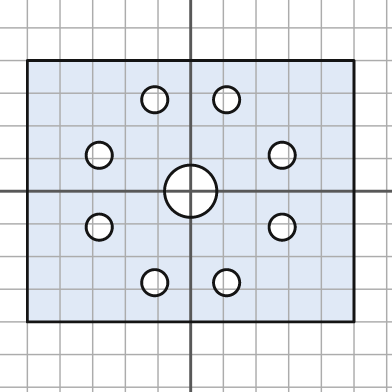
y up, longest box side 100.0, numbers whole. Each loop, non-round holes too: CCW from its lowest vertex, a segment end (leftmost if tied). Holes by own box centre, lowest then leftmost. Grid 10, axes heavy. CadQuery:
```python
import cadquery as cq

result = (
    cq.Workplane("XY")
    .moveTo(-50.0, -40.0)
    .lineTo(50.0, -40.0)
    .lineTo(50.0, 40.0)
    .lineTo(-50.0, 40.0)
    .close()
    .moveTo(-11.0, -28.0)
    .circle(4.0)
    .moveTo(11.0, -28.0)
    .circle(4.0)
    .moveTo(-28.0, -11.0)
    .circle(4.0)
    .moveTo(28.0, -11.0)
    .circle(4.0)
    .moveTo(0.0, 0.0)
    .circle(8.0)
    .moveTo(-28.0, 11.0)
    .circle(4.0)
    .moveTo(28.0, 11.0)
    .circle(4.0)
    .moveTo(-11.0, 28.0)
    .circle(4.0)
    .moveTo(11.0, 28.0)
    .circle(4.0)
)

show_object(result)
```